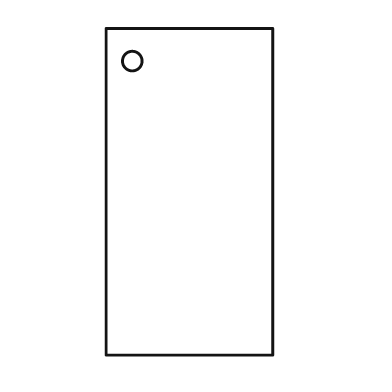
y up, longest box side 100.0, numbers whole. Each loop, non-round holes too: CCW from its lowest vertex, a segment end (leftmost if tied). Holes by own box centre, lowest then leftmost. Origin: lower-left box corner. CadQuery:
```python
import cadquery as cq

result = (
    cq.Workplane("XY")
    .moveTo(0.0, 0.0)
    .lineTo(51.0, 0.0)
    .lineTo(51.0, 100.0)
    .lineTo(0.0, 100.0)
    .close()
    .moveTo(8.0, 90.0)
    .circle(3.0)
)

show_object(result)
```